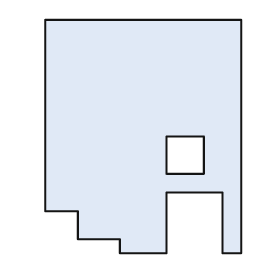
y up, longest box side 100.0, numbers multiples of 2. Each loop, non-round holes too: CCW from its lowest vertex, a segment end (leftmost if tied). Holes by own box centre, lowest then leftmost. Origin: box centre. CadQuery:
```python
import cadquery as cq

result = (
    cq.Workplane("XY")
    .moveTo(-10.0, -50.0)
    .lineTo(10.0, -50.0)
    .lineTo(10.0, -24.0)
    .lineTo(34.0, -24.0)
    .lineTo(34.0, -50.0)
    .lineTo(42.0, -50.0)
    .lineTo(42.0, 50.0)
    .lineTo(-42.0, 50.0)
    .lineTo(-42.0, -32.0)
    .lineTo(-28.0, -32.0)
    .lineTo(-28.0, -44.0)
    .lineTo(-10.0, -44.0)
    .close()
    .moveTo(10.0, -16.0)
    .lineTo(26.0, -16.0)
    .lineTo(26.0, 0.0)
    .lineTo(10.0, 0.0)
    .close()
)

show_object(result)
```